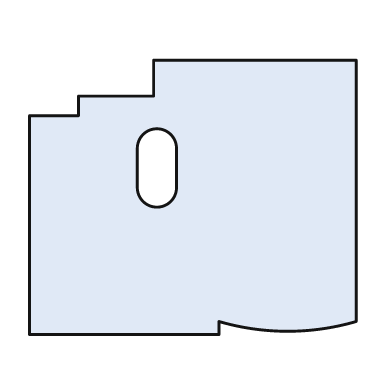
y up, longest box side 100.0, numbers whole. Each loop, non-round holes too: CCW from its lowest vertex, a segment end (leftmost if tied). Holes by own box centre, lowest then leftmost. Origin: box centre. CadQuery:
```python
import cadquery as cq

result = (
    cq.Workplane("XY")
    .moveTo(-50.0, -42.0)
    .lineTo(8.0, -42.0)
    .lineTo(8.0, -38.0)
    .threePointArc((29.0, -41.0), (50.0, -38.0))
    .lineTo(50.0, 42.0)
    .lineTo(-12.0, 42.0)
    .lineTo(-12.0, 31.0)
    .lineTo(-35.0, 31.0)
    .lineTo(-35.0, 25.0)
    .lineTo(-50.0, 25.0)
    .close()
    .moveTo(-17.0, 3.0)
    .threePointArc((-11.0, -3.0), (-5.0, 3.0))
    .lineTo(-5.0, 15.0)
    .threePointArc((-11.0, 21.0), (-17.0, 15.0))
    .close()
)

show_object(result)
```